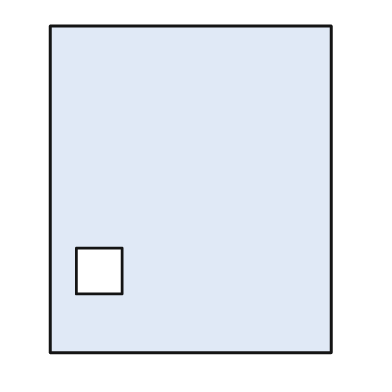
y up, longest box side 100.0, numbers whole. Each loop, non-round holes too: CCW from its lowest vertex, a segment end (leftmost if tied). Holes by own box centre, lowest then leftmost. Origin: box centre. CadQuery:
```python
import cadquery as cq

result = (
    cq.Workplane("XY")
    .moveTo(-43.0, -50.0)
    .lineTo(43.0, -50.0)
    .lineTo(43.0, 50.0)
    .lineTo(-43.0, 50.0)
    .close()
    .moveTo(-35.0, -32.0)
    .lineTo(-21.0, -32.0)
    .lineTo(-21.0, -18.0)
    .lineTo(-35.0, -18.0)
    .close()
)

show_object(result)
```